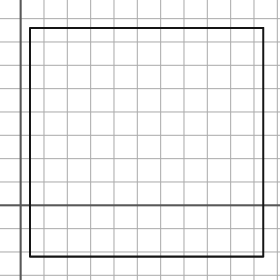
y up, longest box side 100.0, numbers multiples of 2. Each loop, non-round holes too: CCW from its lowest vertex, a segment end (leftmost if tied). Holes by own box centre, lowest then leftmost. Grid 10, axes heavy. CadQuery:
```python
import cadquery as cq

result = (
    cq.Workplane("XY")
    .moveTo(4.0, -22.0)
    .lineTo(104.0, -22.0)
    .lineTo(104.0, 76.0)
    .lineTo(4.0, 76.0)
    .close()
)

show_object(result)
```